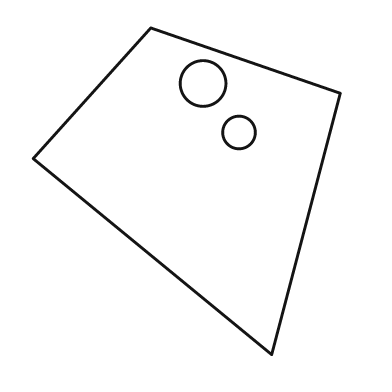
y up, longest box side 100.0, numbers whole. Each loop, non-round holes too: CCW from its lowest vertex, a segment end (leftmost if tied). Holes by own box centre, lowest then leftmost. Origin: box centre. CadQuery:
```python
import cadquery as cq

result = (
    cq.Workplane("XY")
    .moveTo(26.0, -50.0)
    .lineTo(47.0, 30.0)
    .lineTo(-11.0, 50.0)
    .lineTo(-47.0, 10.0)
    .close()
    .moveTo(16.0, 18.0)
    .circle(5.0)
    .moveTo(5.0, 33.0)
    .circle(7.0)
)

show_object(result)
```